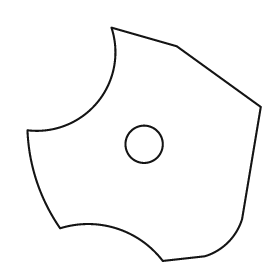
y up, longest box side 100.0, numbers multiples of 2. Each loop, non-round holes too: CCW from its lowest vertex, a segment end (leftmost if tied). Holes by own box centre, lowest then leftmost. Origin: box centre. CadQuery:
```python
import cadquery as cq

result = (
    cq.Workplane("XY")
    .moveTo(8.0, -50.0)
    .lineTo(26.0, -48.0)
    .threePointArc((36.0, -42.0), (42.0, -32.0))
    .lineTo(50.0, 16.0)
    .lineTo(14.0, 42.0)
    .lineTo(-14.0, 50.0)
    .threePointArc((-20.0, 18.0), (-50.0, 6.0))
    .threePointArc((-46.0, -16.0), (-36.0, -36.0))
    .threePointArc((-12.0, -36.0), (8.0, -50.0))
    .close()
    .moveTo(0.0, 0.0)
    .circle(8.0)
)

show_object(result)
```